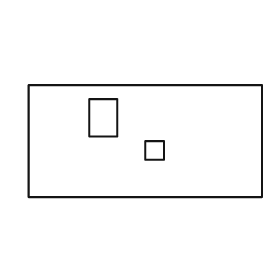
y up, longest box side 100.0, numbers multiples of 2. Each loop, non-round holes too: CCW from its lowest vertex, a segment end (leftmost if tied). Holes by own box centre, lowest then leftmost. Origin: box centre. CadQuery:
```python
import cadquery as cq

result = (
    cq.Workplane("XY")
    .moveTo(-50.0, -24.0)
    .lineTo(50.0, -24.0)
    .lineTo(50.0, 24.0)
    .lineTo(-50.0, 24.0)
    .close()
    .moveTo(0.0, -8.0)
    .lineTo(8.0, -8.0)
    .lineTo(8.0, 0.0)
    .lineTo(0.0, 0.0)
    .close()
    .moveTo(-24.0, 2.0)
    .lineTo(-12.0, 2.0)
    .lineTo(-12.0, 18.0)
    .lineTo(-24.0, 18.0)
    .close()
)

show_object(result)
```